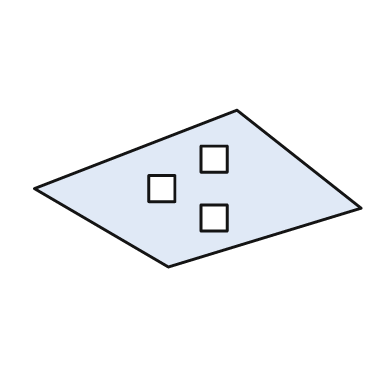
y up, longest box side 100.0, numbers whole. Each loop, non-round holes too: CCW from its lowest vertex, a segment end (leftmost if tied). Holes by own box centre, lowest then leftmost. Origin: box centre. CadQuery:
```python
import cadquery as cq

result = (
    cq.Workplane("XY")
    .moveTo(-9.0, -24.0)
    .lineTo(50.0, -6.0)
    .lineTo(12.0, 24.0)
    .lineTo(-50.0, 0.0)
    .close()
    .moveTo(1.0, -13.0)
    .lineTo(9.0, -13.0)
    .lineTo(9.0, -5.0)
    .lineTo(1.0, -5.0)
    .close()
    .moveTo(-15.0, -4.0)
    .lineTo(-7.0, -4.0)
    .lineTo(-7.0, 4.0)
    .lineTo(-15.0, 4.0)
    .close()
    .moveTo(1.0, 5.0)
    .lineTo(9.0, 5.0)
    .lineTo(9.0, 13.0)
    .lineTo(1.0, 13.0)
    .close()
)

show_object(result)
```